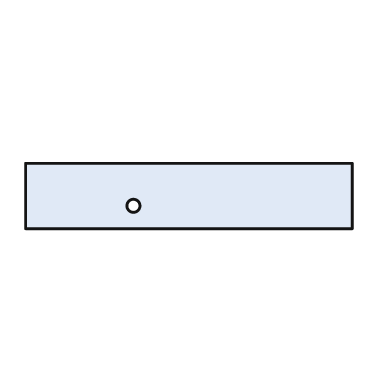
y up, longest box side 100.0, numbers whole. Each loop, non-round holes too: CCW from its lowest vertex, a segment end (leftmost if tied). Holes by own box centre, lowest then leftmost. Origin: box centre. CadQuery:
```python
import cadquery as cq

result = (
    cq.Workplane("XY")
    .moveTo(-50.0, -10.0)
    .lineTo(50.0, -10.0)
    .lineTo(50.0, 10.0)
    .lineTo(-50.0, 10.0)
    .close()
    .moveTo(-17.0, -3.0)
    .circle(2.0)
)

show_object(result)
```